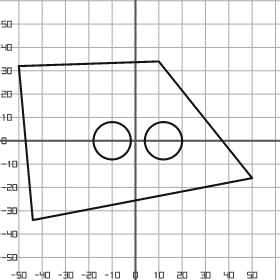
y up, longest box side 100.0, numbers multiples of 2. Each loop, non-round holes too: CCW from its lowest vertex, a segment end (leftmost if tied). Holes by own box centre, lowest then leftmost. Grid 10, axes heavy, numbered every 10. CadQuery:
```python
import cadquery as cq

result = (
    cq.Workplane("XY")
    .moveTo(-44.0, -34.0)
    .lineTo(50.0, -16.0)
    .lineTo(10.0, 34.0)
    .lineTo(-50.0, 32.0)
    .close()
    .moveTo(-10.0, 0.0)
    .circle(8.0)
    .moveTo(12.0, 0.0)
    .circle(8.0)
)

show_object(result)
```